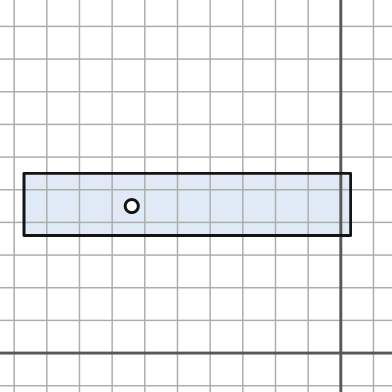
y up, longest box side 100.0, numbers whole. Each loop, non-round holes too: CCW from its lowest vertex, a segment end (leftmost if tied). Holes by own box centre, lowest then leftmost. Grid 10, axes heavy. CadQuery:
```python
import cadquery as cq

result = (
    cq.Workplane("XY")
    .moveTo(-97.0, 36.0)
    .lineTo(3.0, 36.0)
    .lineTo(3.0, 55.0)
    .lineTo(-97.0, 55.0)
    .close()
    .moveTo(-64.0, 45.0)
    .circle(2.0)
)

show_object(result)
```